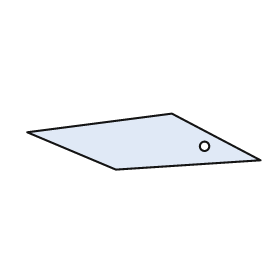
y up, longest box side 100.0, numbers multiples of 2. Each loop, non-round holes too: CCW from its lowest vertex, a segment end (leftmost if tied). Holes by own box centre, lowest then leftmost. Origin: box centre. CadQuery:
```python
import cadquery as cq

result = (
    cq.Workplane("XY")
    .moveTo(-12.0, -12.0)
    .lineTo(50.0, -8.0)
    .lineTo(12.0, 12.0)
    .lineTo(-50.0, 4.0)
    .close()
    .moveTo(26.0, -2.0)
    .circle(2.0)
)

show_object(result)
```